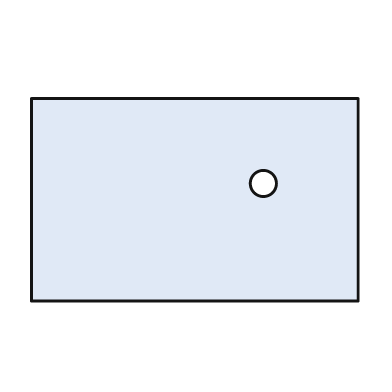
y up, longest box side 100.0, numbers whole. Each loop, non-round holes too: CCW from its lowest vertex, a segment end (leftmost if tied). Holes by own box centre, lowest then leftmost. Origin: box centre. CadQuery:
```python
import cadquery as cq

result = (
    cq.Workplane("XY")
    .moveTo(-50.0, -31.0)
    .lineTo(50.0, -31.0)
    .lineTo(50.0, 31.0)
    .lineTo(-50.0, 31.0)
    .close()
    .moveTo(21.0, 5.0)
    .circle(4.0)
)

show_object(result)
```